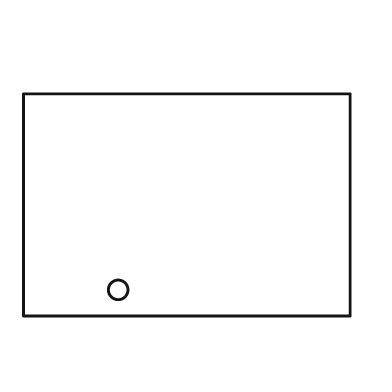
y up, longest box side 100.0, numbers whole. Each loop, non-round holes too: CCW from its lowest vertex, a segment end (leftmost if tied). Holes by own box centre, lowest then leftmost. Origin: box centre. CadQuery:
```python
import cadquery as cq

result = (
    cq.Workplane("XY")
    .moveTo(-50.0, -34.0)
    .lineTo(50.0, -34.0)
    .lineTo(50.0, 34.0)
    .lineTo(-50.0, 34.0)
    .close()
    .moveTo(-21.0, -26.0)
    .circle(3.0)
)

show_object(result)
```